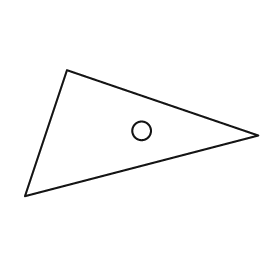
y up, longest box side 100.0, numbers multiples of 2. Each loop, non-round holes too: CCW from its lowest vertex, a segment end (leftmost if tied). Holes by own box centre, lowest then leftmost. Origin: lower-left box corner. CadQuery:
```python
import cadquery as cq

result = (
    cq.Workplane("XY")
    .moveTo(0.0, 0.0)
    .lineTo(100.0, 26.0)
    .lineTo(18.0, 54.0)
    .close()
    .moveTo(50.0, 28.0)
    .circle(4.0)
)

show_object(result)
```